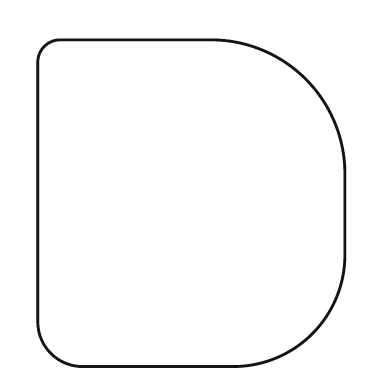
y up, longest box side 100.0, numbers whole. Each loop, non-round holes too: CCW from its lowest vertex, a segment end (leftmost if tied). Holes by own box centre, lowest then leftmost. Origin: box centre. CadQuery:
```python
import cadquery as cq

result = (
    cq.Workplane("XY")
    .moveTo(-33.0, -50.0)
    .lineTo(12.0, -50.0)
    .threePointArc((37.0, -40.0), (47.0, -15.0))
    .lineTo(47.0, 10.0)
    .threePointArc((35.0, 38.0), (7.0, 50.0))
    .lineTo(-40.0, 50.0)
    .threePointArc((-45.0, 48.0), (-47.0, 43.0))
    .lineTo(-47.0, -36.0)
    .threePointArc((-43.0, -46.0), (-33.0, -50.0))
    .close()
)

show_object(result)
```